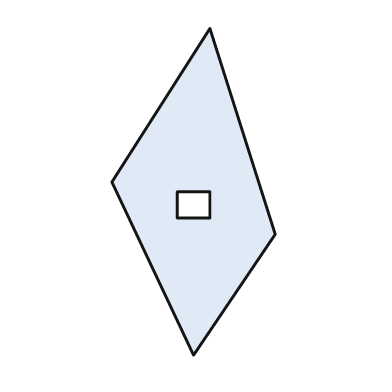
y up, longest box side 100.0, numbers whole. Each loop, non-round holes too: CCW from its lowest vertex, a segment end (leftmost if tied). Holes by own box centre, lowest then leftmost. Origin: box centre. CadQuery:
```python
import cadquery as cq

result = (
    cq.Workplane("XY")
    .moveTo(0.0, -50.0)
    .lineTo(25.0, -13.0)
    .lineTo(5.0, 50.0)
    .lineTo(-25.0, 3.0)
    .close()
    .moveTo(-5.0, -8.0)
    .lineTo(5.0, -8.0)
    .lineTo(5.0, 0.0)
    .lineTo(-5.0, 0.0)
    .close()
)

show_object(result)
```